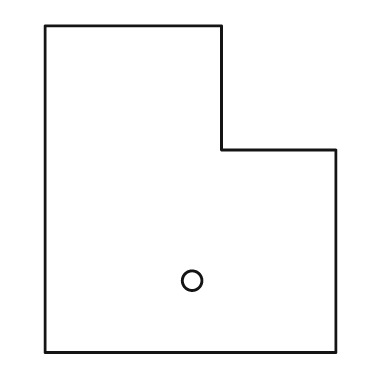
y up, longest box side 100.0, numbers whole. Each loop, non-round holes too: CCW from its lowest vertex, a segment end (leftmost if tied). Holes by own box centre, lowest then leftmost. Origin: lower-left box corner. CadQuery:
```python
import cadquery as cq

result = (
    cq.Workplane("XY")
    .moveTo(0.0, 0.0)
    .lineTo(89.0, 0.0)
    .lineTo(89.0, 62.0)
    .lineTo(54.0, 62.0)
    .lineTo(54.0, 100.0)
    .lineTo(0.0, 100.0)
    .close()
    .moveTo(45.0, 22.0)
    .circle(3.0)
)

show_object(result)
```